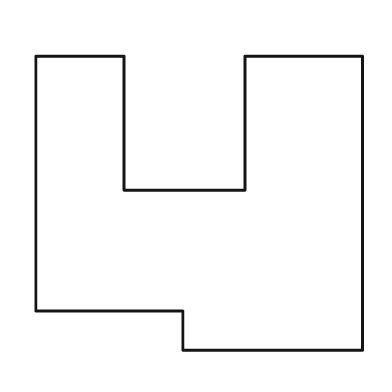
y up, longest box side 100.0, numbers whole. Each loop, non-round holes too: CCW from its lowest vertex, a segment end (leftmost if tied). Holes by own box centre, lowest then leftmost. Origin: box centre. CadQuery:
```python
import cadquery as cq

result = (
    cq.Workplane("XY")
    .moveTo(-5.0, -45.0)
    .lineTo(50.0, -45.0)
    .lineTo(50.0, 45.0)
    .lineTo(14.0, 45.0)
    .lineTo(14.0, 4.0)
    .lineTo(-23.0, 4.0)
    .lineTo(-23.0, 45.0)
    .lineTo(-50.0, 45.0)
    .lineTo(-50.0, -33.0)
    .lineTo(-5.0, -33.0)
    .close()
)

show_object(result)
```